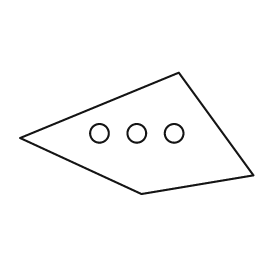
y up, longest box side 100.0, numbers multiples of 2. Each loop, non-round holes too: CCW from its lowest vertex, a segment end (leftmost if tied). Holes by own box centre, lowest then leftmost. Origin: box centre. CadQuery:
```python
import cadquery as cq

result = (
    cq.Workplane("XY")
    .moveTo(2.0, -26.0)
    .lineTo(50.0, -18.0)
    .lineTo(18.0, 26.0)
    .lineTo(-50.0, -2.0)
    .close()
    .moveTo(-16.0, 0.0)
    .circle(4.0)
    .moveTo(0.0, 0.0)
    .circle(4.0)
    .moveTo(16.0, 0.0)
    .circle(4.0)
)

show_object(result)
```